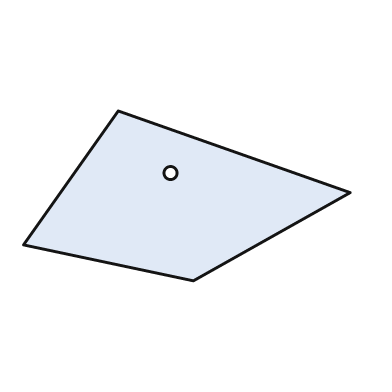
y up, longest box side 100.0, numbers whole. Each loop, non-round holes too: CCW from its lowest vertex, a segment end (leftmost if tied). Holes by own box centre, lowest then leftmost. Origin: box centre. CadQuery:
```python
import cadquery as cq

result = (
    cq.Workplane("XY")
    .moveTo(2.0, -26.0)
    .lineTo(50.0, 1.0)
    .lineTo(-21.0, 26.0)
    .lineTo(-50.0, -15.0)
    .close()
    .moveTo(-5.0, 7.0)
    .circle(2.0)
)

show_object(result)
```